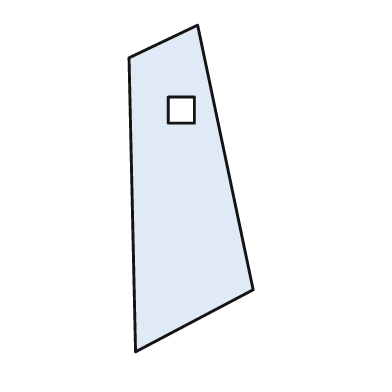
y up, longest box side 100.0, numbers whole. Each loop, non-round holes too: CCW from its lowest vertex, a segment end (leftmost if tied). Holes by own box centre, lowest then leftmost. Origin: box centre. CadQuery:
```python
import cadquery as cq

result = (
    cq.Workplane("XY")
    .moveTo(-17.0, -50.0)
    .lineTo(19.0, -31.0)
    .lineTo(2.0, 50.0)
    .lineTo(-19.0, 40.0)
    .close()
    .moveTo(-7.0, 20.0)
    .lineTo(1.0, 20.0)
    .lineTo(1.0, 28.0)
    .lineTo(-7.0, 28.0)
    .close()
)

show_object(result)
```